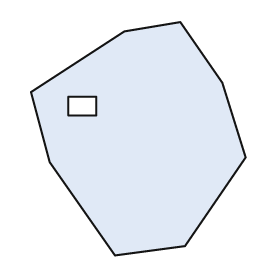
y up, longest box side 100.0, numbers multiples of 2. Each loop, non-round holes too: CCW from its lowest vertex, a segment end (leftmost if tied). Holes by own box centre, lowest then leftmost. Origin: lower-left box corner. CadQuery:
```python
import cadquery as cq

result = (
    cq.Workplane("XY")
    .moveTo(36.0, 0.0)
    .lineTo(66.0, 4.0)
    .lineTo(92.0, 42.0)
    .lineTo(82.0, 74.0)
    .lineTo(64.0, 100.0)
    .lineTo(40.0, 96.0)
    .lineTo(0.0, 70.0)
    .lineTo(8.0, 40.0)
    .close()
    .moveTo(16.0, 60.0)
    .lineTo(28.0, 60.0)
    .lineTo(28.0, 68.0)
    .lineTo(16.0, 68.0)
    .close()
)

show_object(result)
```